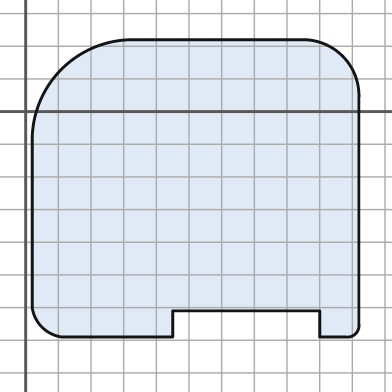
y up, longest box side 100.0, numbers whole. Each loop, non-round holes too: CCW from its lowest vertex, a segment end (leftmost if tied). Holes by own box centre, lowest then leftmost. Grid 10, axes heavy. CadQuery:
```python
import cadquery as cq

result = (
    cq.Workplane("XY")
    .moveTo(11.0, -69.0)
    .lineTo(45.0, -69.0)
    .lineTo(45.0, -61.0)
    .lineTo(90.0, -61.0)
    .lineTo(90.0, -69.0)
    .lineTo(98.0, -69.0)
    .threePointArc((101.0, -68.0), (102.0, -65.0))
    .lineTo(102.0, 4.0)
    .threePointArc((97.0, 17.0), (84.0, 22.0))
    .lineTo(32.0, 22.0)
    .threePointArc((11.0, 13.0), (2.0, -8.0))
    .lineTo(2.0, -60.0)
    .threePointArc((5.0, -66.0), (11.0, -69.0))
    .close()
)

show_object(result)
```